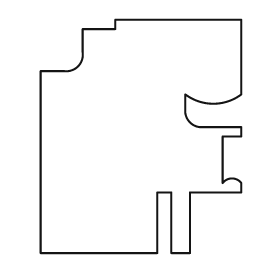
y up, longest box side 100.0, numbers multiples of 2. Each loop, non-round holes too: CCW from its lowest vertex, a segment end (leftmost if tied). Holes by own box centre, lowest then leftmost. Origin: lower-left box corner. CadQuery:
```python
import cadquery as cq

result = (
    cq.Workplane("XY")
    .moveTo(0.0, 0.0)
    .lineTo(50.0, 0.0)
    .lineTo(50.0, 26.0)
    .lineTo(56.0, 26.0)
    .lineTo(56.0, 0.0)
    .lineTo(64.0, 0.0)
    .lineTo(64.0, 26.0)
    .lineTo(86.0, 26.0)
    .lineTo(86.0, 30.0)
    .threePointArc((82.0, 32.0), (78.0, 30.0))
    .lineTo(78.0, 50.0)
    .lineTo(86.0, 50.0)
    .lineTo(86.0, 54.0)
    .lineTo(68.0, 54.0)
    .threePointArc((64.0, 56.0), (62.0, 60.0))
    .lineTo(62.0, 68.0)
    .threePointArc((74.0, 64.0), (86.0, 68.0))
    .lineTo(86.0, 100.0)
    .lineTo(32.0, 100.0)
    .lineTo(32.0, 96.0)
    .lineTo(18.0, 96.0)
    .lineTo(18.0, 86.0)
    .threePointArc((16.0, 80.0), (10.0, 78.0))
    .lineTo(0.0, 78.0)
    .close()
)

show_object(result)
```